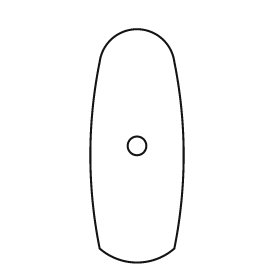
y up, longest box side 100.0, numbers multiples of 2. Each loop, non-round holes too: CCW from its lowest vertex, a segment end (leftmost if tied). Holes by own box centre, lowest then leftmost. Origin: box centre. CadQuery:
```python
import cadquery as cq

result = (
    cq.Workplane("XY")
    .moveTo(-16.0, -44.0)
    .threePointArc((0.0, -50.0), (16.0, -44.0))
    .threePointArc((20.0, -4.0), (16.0, 36.0))
    .threePointArc((0.0, 50.0), (-16.0, 36.0))
    .threePointArc((-20.0, -4.0), (-16.0, -44.0))
    .close()
    .moveTo(0.0, 0.0)
    .circle(4.0)
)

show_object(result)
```